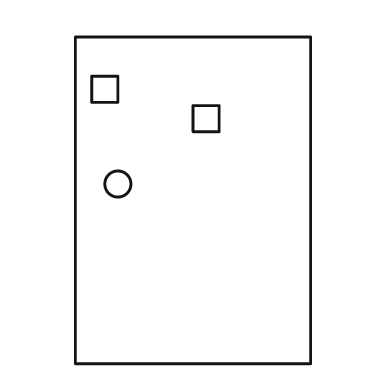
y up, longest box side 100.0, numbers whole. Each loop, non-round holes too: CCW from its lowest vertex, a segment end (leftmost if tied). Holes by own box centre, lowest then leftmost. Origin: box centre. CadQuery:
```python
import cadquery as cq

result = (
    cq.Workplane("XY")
    .moveTo(-36.0, -50.0)
    .lineTo(36.0, -50.0)
    .lineTo(36.0, 50.0)
    .lineTo(-36.0, 50.0)
    .close()
    .moveTo(-23.0, 5.0)
    .circle(4.0)
    .moveTo(0.0, 21.0)
    .lineTo(8.0, 21.0)
    .lineTo(8.0, 29.0)
    .lineTo(0.0, 29.0)
    .close()
    .moveTo(-31.0, 30.0)
    .lineTo(-23.0, 30.0)
    .lineTo(-23.0, 38.0)
    .lineTo(-31.0, 38.0)
    .close()
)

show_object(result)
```